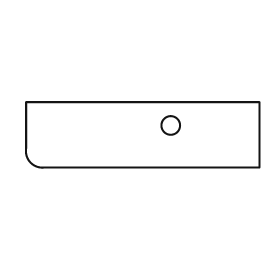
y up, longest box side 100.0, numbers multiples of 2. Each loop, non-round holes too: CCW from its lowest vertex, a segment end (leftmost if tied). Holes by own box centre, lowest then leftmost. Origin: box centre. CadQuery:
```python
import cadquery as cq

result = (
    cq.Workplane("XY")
    .moveTo(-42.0, -14.0)
    .lineTo(50.0, -14.0)
    .lineTo(50.0, 14.0)
    .lineTo(-50.0, 14.0)
    .lineTo(-50.0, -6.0)
    .threePointArc((-48.0, -12.0), (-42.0, -14.0))
    .close()
    .moveTo(12.0, 4.0)
    .circle(4.0)
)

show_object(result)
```